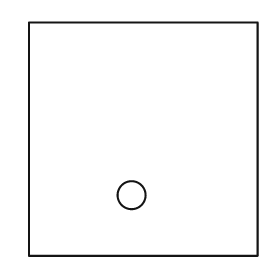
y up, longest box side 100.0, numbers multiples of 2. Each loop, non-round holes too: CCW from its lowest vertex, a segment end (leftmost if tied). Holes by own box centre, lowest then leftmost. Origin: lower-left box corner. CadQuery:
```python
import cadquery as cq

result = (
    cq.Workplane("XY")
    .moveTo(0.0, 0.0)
    .lineTo(98.0, 0.0)
    .lineTo(98.0, 100.0)
    .lineTo(0.0, 100.0)
    .close()
    .moveTo(44.0, 26.0)
    .circle(6.0)
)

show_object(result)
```